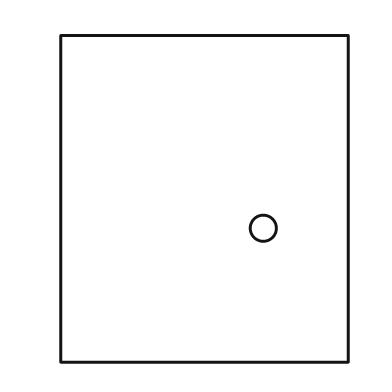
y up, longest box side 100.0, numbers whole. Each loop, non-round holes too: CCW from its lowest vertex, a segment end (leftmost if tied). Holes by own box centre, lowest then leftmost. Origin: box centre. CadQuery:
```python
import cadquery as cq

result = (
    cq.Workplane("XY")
    .moveTo(-44.0, -50.0)
    .lineTo(44.0, -50.0)
    .lineTo(44.0, 50.0)
    .lineTo(-44.0, 50.0)
    .close()
    .moveTo(18.0, -9.0)
    .circle(4.0)
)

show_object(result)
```